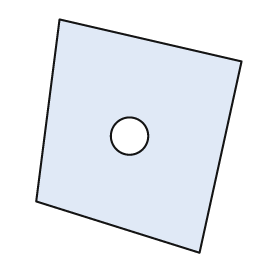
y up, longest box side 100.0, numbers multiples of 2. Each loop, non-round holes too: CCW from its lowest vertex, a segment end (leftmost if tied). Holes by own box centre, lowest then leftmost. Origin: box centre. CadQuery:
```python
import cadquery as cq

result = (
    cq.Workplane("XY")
    .moveTo(26.0, -50.0)
    .lineTo(44.0, 32.0)
    .lineTo(-34.0, 50.0)
    .lineTo(-44.0, -28.0)
    .close()
    .moveTo(-4.0, 0.0)
    .circle(8.0)
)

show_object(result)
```